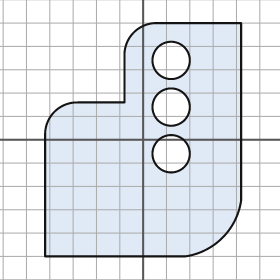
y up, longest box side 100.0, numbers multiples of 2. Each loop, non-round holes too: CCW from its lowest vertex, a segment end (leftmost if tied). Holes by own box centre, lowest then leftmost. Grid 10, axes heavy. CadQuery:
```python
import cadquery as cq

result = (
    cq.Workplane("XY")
    .moveTo(-42.0, -50.0)
    .lineTo(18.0, -50.0)
    .threePointArc((34.0, -42.0), (42.0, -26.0))
    .lineTo(42.0, 50.0)
    .lineTo(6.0, 50.0)
    .threePointArc((-4.0, 46.0), (-8.0, 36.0))
    .lineTo(-8.0, 16.0)
    .lineTo(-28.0, 16.0)
    .threePointArc((-38.0, 12.0), (-42.0, 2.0))
    .close()
    .moveTo(12.0, -6.0)
    .circle(8.0)
    .moveTo(12.0, 14.0)
    .circle(8.0)
    .moveTo(12.0, 34.0)
    .circle(8.0)
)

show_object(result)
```